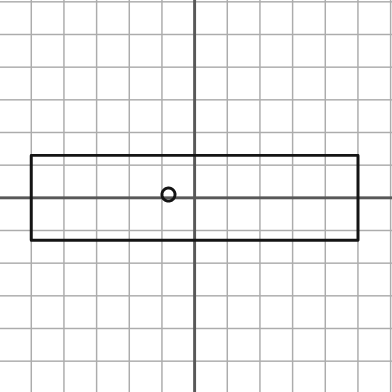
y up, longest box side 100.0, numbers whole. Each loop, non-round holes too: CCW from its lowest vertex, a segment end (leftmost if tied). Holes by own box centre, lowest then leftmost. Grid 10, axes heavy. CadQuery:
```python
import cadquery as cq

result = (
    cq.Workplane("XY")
    .moveTo(-50.0, -13.0)
    .lineTo(50.0, -13.0)
    .lineTo(50.0, 13.0)
    .lineTo(-50.0, 13.0)
    .close()
    .moveTo(-8.0, 1.0)
    .circle(2.0)
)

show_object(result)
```